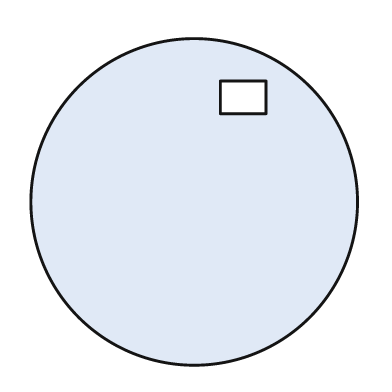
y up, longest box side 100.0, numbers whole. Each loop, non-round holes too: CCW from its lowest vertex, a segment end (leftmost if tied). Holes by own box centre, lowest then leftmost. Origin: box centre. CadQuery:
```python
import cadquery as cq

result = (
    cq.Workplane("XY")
    .moveTo(0.0, 0.0)
    .circle(50.0)
    .moveTo(8.0, 27.0)
    .lineTo(22.0, 27.0)
    .lineTo(22.0, 37.0)
    .lineTo(8.0, 37.0)
    .close()
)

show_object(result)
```